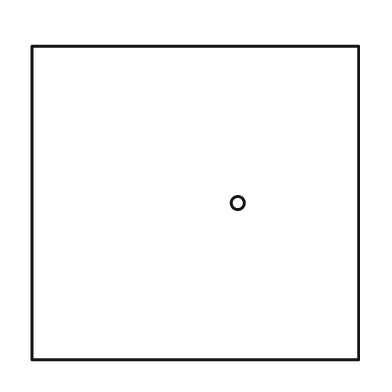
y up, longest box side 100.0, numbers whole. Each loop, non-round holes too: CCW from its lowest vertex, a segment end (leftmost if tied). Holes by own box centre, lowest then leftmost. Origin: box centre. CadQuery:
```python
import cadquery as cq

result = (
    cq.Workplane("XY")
    .moveTo(-50.0, -48.0)
    .lineTo(50.0, -48.0)
    .lineTo(50.0, 48.0)
    .lineTo(-50.0, 48.0)
    .close()
    .moveTo(13.0, 0.0)
    .circle(2.0)
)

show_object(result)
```